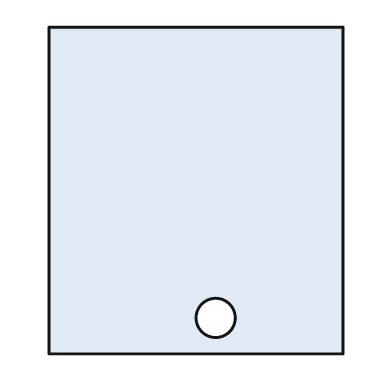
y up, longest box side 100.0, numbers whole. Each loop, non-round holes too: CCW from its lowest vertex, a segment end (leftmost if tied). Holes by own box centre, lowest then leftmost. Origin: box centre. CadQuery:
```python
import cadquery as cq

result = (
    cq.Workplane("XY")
    .moveTo(-45.0, -50.0)
    .lineTo(45.0, -50.0)
    .lineTo(45.0, 50.0)
    .lineTo(-45.0, 50.0)
    .close()
    .moveTo(6.0, -39.0)
    .circle(6.0)
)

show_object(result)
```